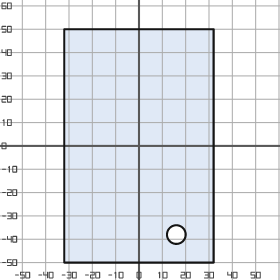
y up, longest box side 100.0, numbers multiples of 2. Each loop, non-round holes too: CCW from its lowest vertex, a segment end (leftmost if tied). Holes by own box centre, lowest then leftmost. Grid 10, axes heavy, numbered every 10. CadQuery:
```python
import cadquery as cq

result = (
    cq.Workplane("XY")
    .moveTo(-32.0, -50.0)
    .lineTo(32.0, -50.0)
    .lineTo(32.0, 50.0)
    .lineTo(-32.0, 50.0)
    .close()
    .moveTo(16.0, -38.0)
    .circle(4.0)
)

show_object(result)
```